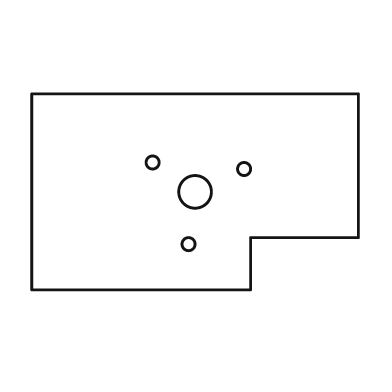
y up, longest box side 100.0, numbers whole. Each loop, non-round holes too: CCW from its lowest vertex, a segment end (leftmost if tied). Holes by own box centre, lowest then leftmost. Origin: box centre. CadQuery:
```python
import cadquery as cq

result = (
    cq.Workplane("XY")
    .moveTo(-50.0, -30.0)
    .lineTo(17.0, -30.0)
    .lineTo(17.0, -14.0)
    .lineTo(50.0, -14.0)
    .lineTo(50.0, 30.0)
    .lineTo(-50.0, 30.0)
    .close()
    .moveTo(-2.0, -16.0)
    .circle(2.0)
    .moveTo(0.0, 0.0)
    .circle(5.0)
    .moveTo(15.0, 7.0)
    .circle(2.0)
    .moveTo(-13.0, 9.0)
    .circle(2.0)
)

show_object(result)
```